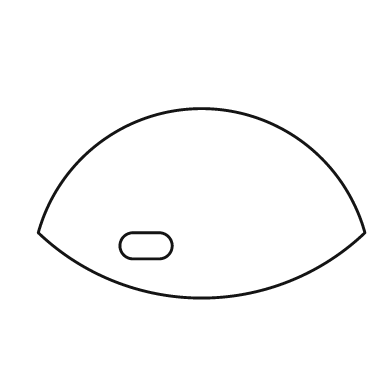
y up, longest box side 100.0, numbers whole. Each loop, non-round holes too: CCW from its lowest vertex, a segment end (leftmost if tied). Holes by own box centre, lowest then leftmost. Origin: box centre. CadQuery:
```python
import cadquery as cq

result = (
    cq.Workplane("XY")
    .moveTo(-50.0, -9.0)
    .threePointArc((0.0, -29.0), (50.0, -9.0))
    .threePointArc((0.0, 29.0), (-50.0, -9.0))
    .close()
    .moveTo(-21.0, -17.0)
    .lineTo(-13.0, -17.0)
    .threePointArc((-9.0, -13.0), (-13.0, -9.0))
    .lineTo(-21.0, -9.0)
    .threePointArc((-25.0, -13.0), (-21.0, -17.0))
    .close()
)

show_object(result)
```